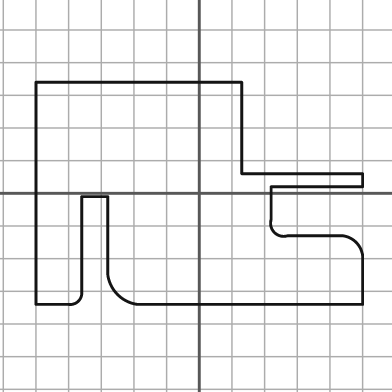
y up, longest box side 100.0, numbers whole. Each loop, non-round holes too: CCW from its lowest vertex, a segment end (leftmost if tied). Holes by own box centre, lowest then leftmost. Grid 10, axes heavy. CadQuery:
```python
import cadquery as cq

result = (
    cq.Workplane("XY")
    .moveTo(-50.0, -34.0)
    .lineTo(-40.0, -34.0)
    .threePointArc((-37.0, -33.0), (-36.0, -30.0))
    .lineTo(-36.0, -1.0)
    .lineTo(-28.0, -1.0)
    .lineTo(-28.0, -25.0)
    .threePointArc((-25.0, -31.0), (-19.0, -34.0))
    .lineTo(50.0, -34.0)
    .lineTo(50.0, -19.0)
    .threePointArc((48.0, -15.0), (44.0, -13.0))
    .lineTo(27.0, -13.0)
    .threePointArc((23.0, -12.0), (22.0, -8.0))
    .lineTo(22.0, 2.0)
    .lineTo(50.0, 2.0)
    .lineTo(50.0, 6.0)
    .lineTo(13.0, 6.0)
    .lineTo(13.0, 34.0)
    .lineTo(-50.0, 34.0)
    .close()
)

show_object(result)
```